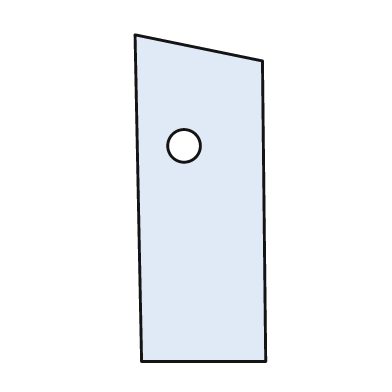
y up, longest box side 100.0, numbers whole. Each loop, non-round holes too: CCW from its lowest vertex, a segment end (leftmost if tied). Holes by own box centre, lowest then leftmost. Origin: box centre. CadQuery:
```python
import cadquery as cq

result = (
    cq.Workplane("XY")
    .moveTo(-18.0, -50.0)
    .lineTo(20.0, -50.0)
    .lineTo(19.0, 42.0)
    .lineTo(-20.0, 50.0)
    .close()
    .moveTo(-5.0, 16.0)
    .circle(5.0)
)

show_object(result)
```